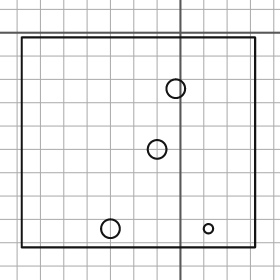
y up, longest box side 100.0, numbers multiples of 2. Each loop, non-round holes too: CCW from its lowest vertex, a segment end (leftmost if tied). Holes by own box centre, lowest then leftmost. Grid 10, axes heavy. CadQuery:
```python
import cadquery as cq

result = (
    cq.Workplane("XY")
    .moveTo(-68.0, -92.0)
    .lineTo(32.0, -92.0)
    .lineTo(32.0, -2.0)
    .lineTo(-68.0, -2.0)
    .close()
    .moveTo(-30.0, -84.0)
    .circle(4.0)
    .moveTo(12.0, -84.0)
    .circle(2.0)
    .moveTo(-10.0, -50.0)
    .circle(4.0)
    .moveTo(-2.0, -24.0)
    .circle(4.0)
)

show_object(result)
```